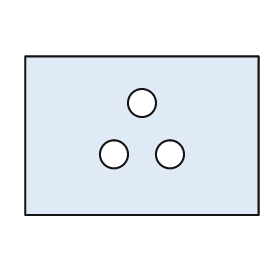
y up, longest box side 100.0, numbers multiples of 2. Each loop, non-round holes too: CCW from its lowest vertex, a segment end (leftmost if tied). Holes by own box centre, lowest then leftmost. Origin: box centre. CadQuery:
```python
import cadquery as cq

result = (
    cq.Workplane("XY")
    .moveTo(-50.0, -34.0)
    .lineTo(50.0, -34.0)
    .lineTo(50.0, 34.0)
    .lineTo(-50.0, 34.0)
    .close()
    .moveTo(-12.0, -8.0)
    .circle(6.0)
    .moveTo(12.0, -8.0)
    .circle(6.0)
    .moveTo(0.0, 14.0)
    .circle(6.0)
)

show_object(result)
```